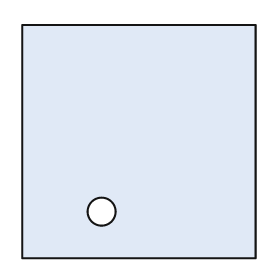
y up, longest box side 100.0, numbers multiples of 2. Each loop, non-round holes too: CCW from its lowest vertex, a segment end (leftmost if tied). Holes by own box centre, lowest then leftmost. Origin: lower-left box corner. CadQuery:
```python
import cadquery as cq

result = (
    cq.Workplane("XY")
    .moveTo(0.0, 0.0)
    .lineTo(100.0, 0.0)
    .lineTo(100.0, 100.0)
    .lineTo(0.0, 100.0)
    .close()
    .moveTo(34.0, 20.0)
    .circle(6.0)
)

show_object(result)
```